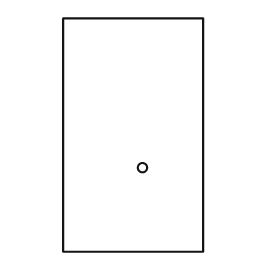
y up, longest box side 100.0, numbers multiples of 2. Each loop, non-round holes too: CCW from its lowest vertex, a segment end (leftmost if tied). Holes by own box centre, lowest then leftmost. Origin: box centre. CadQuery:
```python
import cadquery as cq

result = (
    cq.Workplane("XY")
    .moveTo(-30.0, -50.0)
    .lineTo(30.0, -50.0)
    .lineTo(30.0, 50.0)
    .lineTo(-30.0, 50.0)
    .close()
    .moveTo(4.0, -14.0)
    .circle(2.0)
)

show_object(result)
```